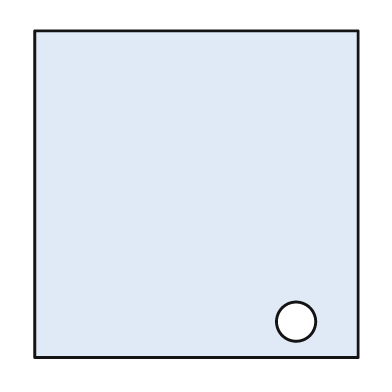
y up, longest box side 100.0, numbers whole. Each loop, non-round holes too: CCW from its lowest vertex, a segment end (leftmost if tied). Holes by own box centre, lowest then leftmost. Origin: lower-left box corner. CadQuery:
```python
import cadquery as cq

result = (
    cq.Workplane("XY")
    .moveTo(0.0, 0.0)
    .lineTo(99.0, 0.0)
    .lineTo(99.0, 100.0)
    .lineTo(0.0, 100.0)
    .close()
    .moveTo(80.0, 11.0)
    .circle(6.0)
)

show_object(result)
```